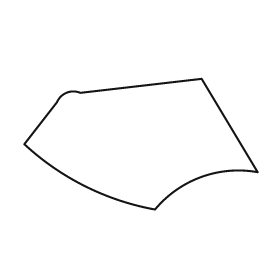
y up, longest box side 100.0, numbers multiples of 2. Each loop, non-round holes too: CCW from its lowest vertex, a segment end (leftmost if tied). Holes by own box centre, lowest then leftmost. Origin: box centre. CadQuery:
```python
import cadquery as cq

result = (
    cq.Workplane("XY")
    .moveTo(6.0, -28.0)
    .threePointArc((26.0, -14.0), (50.0, -12.0))
    .lineTo(26.0, 28.0)
    .lineTo(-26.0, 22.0)
    .threePointArc((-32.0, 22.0), (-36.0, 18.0))
    .lineTo(-50.0, 0.0)
    .threePointArc((-24.0, -18.0), (6.0, -28.0))
    .close()
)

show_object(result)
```